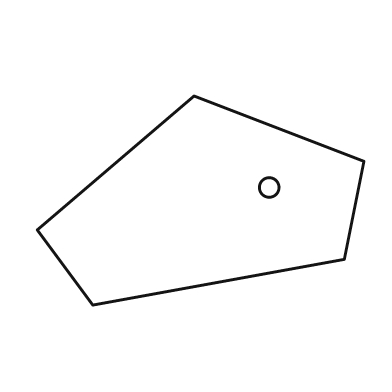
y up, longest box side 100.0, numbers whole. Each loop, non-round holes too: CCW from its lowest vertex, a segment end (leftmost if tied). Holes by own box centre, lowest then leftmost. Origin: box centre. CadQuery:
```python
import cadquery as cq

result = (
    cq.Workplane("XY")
    .moveTo(-33.0, -32.0)
    .lineTo(44.0, -18.0)
    .lineTo(50.0, 12.0)
    .lineTo(-2.0, 32.0)
    .lineTo(-50.0, -9.0)
    .close()
    .moveTo(21.0, 4.0)
    .circle(3.0)
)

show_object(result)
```